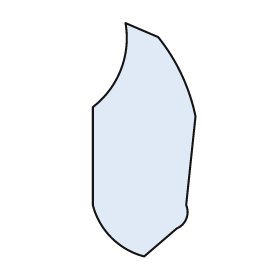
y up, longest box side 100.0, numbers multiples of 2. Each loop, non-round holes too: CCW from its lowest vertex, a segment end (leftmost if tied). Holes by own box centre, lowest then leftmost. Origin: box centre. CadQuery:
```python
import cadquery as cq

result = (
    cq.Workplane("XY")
    .moveTo(0.0, -50.0)
    .lineTo(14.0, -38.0)
    .threePointArc((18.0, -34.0), (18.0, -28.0))
    .lineTo(22.0, 10.0)
    .threePointArc((16.0, 28.0), (6.0, 44.0))
    .lineTo(-8.0, 50.0)
    .threePointArc((-10.0, 30.0), (-22.0, 14.0))
    .lineTo(-22.0, -28.0)
    .threePointArc((-14.0, -42.0), (0.0, -50.0))
    .close()
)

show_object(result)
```